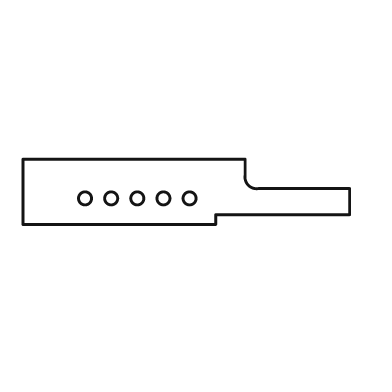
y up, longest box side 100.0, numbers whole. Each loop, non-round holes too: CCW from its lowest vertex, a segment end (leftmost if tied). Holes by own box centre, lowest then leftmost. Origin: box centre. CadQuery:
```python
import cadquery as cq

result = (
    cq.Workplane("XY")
    .moveTo(-50.0, -10.0)
    .lineTo(9.0, -10.0)
    .lineTo(9.0, -7.0)
    .lineTo(50.0, -7.0)
    .lineTo(50.0, 1.0)
    .lineTo(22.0, 1.0)
    .threePointArc((19.0, 2.0), (18.0, 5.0))
    .lineTo(18.0, 10.0)
    .lineTo(-50.0, 10.0)
    .close()
    .moveTo(-31.0, -2.0)
    .circle(2.0)
    .moveTo(-23.0, -2.0)
    .circle(2.0)
    .moveTo(-15.0, -2.0)
    .circle(2.0)
    .moveTo(-7.0, -2.0)
    .circle(2.0)
    .moveTo(1.0, -2.0)
    .circle(2.0)
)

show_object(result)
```